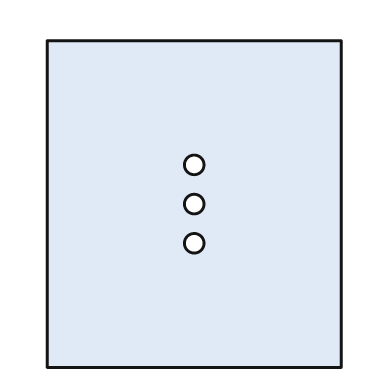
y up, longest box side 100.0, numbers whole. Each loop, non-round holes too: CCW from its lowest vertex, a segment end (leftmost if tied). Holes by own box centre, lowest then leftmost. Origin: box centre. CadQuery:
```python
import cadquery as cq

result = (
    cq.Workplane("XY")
    .moveTo(-45.0, -50.0)
    .lineTo(45.0, -50.0)
    .lineTo(45.0, 50.0)
    .lineTo(-45.0, 50.0)
    .close()
    .moveTo(0.0, -12.0)
    .circle(3.0)
    .moveTo(0.0, 0.0)
    .circle(3.0)
    .moveTo(0.0, 12.0)
    .circle(3.0)
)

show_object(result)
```